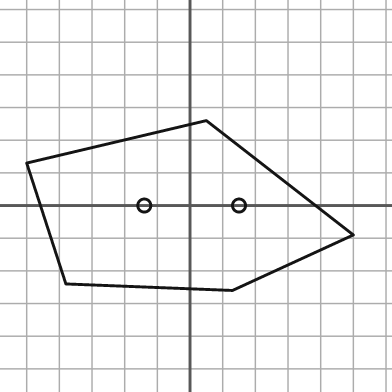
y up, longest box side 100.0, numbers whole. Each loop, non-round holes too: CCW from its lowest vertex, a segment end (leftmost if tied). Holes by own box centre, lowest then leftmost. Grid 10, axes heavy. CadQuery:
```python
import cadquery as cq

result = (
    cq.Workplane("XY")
    .moveTo(13.0, -26.0)
    .lineTo(50.0, -9.0)
    .lineTo(5.0, 26.0)
    .lineTo(-50.0, 13.0)
    .lineTo(-38.0, -24.0)
    .close()
    .moveTo(-14.0, 0.0)
    .circle(2.0)
    .moveTo(15.0, 0.0)
    .circle(2.0)
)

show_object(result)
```